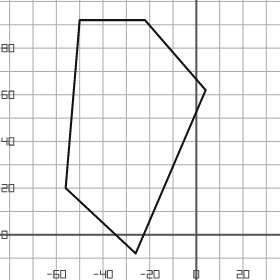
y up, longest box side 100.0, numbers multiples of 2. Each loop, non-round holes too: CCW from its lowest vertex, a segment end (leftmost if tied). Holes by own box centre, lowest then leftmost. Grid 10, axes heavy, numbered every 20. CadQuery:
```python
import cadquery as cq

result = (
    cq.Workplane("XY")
    .moveTo(-26.0, -8.0)
    .lineTo(4.0, 62.0)
    .lineTo(-22.0, 92.0)
    .lineTo(-50.0, 92.0)
    .lineTo(-56.0, 20.0)
    .close()
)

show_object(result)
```